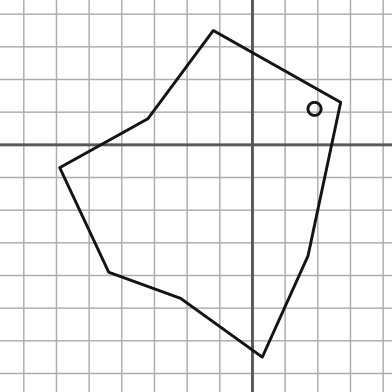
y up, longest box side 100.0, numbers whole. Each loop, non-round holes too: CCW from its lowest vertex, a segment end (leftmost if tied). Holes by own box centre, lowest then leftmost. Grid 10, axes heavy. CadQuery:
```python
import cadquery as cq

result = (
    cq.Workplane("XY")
    .moveTo(3.0, -65.0)
    .lineTo(17.0, -34.0)
    .lineTo(27.0, 13.0)
    .lineTo(-12.0, 35.0)
    .lineTo(-32.0, 8.0)
    .lineTo(-59.0, -7.0)
    .lineTo(-44.0, -39.0)
    .lineTo(-22.0, -47.0)
    .close()
    .moveTo(19.0, 11.0)
    .circle(2.0)
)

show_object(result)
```